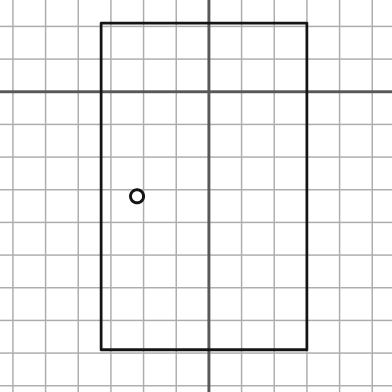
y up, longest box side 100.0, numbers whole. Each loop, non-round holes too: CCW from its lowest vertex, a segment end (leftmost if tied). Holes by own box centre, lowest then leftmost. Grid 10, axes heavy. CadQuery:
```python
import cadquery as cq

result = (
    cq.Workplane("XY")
    .moveTo(-33.0, -79.0)
    .lineTo(30.0, -79.0)
    .lineTo(30.0, 21.0)
    .lineTo(-33.0, 21.0)
    .close()
    .moveTo(-22.0, -32.0)
    .circle(2.0)
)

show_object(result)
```